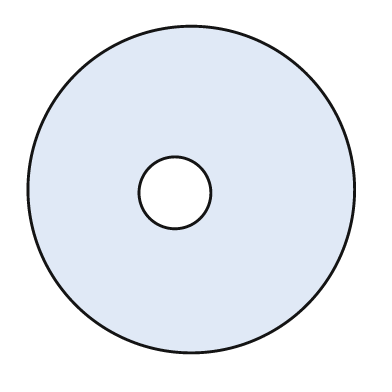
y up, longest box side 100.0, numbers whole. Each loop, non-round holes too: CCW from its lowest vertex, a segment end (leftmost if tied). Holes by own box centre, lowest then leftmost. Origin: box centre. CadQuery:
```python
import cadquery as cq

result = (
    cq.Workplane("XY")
    .moveTo(0.0, 0.0)
    .circle(50.0)
    .moveTo(-5.0, -1.0)
    .circle(11.0)
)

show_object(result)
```